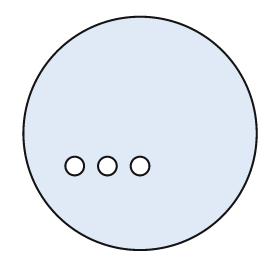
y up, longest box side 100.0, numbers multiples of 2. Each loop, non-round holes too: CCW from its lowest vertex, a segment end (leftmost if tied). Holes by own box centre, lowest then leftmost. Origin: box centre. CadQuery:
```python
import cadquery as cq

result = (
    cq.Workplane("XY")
    .moveTo(0.0, 0.0)
    .circle(50.0)
    .moveTo(-28.0, -14.0)
    .circle(4.0)
    .moveTo(-14.0, -14.0)
    .circle(4.0)
    .moveTo(0.0, -14.0)
    .circle(4.0)
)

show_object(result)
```